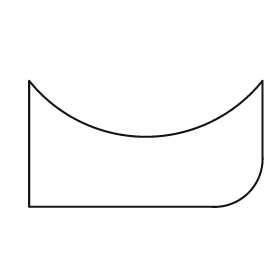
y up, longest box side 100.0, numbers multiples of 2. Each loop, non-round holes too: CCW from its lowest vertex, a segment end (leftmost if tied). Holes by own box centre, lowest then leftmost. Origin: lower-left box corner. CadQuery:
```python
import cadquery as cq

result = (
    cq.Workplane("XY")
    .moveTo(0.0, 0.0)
    .lineTo(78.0, 0.0)
    .threePointArc((94.0, 6.0), (100.0, 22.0))
    .lineTo(100.0, 54.0)
    .threePointArc((50.0, 30.0), (0.0, 54.0))
    .close()
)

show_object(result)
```